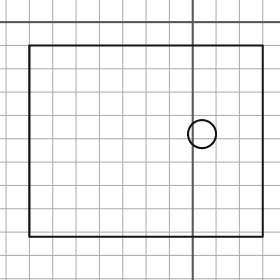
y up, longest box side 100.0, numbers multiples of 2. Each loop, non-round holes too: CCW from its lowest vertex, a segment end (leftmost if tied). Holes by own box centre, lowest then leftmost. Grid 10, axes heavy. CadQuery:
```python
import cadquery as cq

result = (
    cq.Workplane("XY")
    .moveTo(-70.0, -92.0)
    .lineTo(30.0, -92.0)
    .lineTo(30.0, -10.0)
    .lineTo(-70.0, -10.0)
    .close()
    .moveTo(4.0, -48.0)
    .circle(6.0)
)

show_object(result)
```